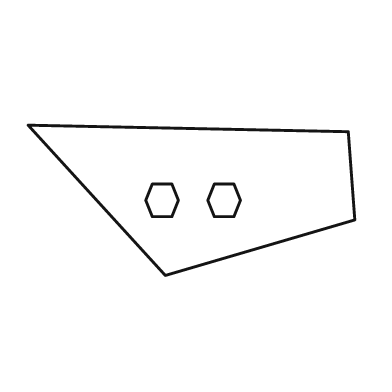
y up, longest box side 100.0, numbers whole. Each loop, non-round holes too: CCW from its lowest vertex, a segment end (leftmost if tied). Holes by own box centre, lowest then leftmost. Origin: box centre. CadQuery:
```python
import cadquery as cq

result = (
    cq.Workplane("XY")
    .moveTo(-8.0, -23.0)
    .lineTo(50.0, -6.0)
    .lineTo(48.0, 21.0)
    .lineTo(-50.0, 23.0)
    .close()
    .moveTo(-12.0, -5.0)
    .lineTo(-6.0, -5.0)
    .lineTo(-4.0, 0.0)
    .lineTo(-6.0, 5.0)
    .lineTo(-12.0, 5.0)
    .lineTo(-14.0, 0.0)
    .close()
    .moveTo(7.0, -5.0)
    .lineTo(13.0, -5.0)
    .lineTo(15.0, 0.0)
    .lineTo(13.0, 5.0)
    .lineTo(7.0, 5.0)
    .lineTo(5.0, 0.0)
    .close()
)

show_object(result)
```